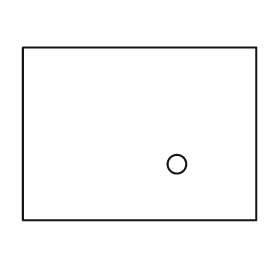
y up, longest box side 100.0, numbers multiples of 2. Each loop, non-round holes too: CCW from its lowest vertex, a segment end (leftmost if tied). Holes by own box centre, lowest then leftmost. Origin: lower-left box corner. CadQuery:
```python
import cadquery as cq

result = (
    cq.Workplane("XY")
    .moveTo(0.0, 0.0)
    .lineTo(100.0, 0.0)
    .lineTo(100.0, 74.0)
    .lineTo(0.0, 74.0)
    .close()
    .moveTo(66.0, 24.0)
    .circle(4.0)
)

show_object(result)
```